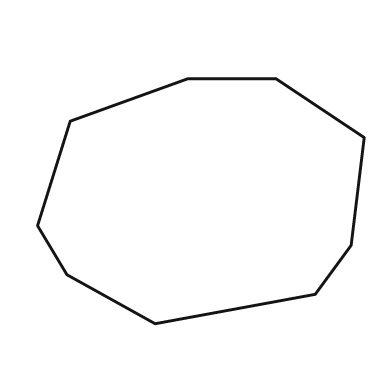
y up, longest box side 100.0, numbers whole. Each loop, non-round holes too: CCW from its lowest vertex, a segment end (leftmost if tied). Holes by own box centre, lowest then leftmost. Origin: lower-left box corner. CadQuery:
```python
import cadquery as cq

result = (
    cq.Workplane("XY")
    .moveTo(36.0, 0.0)
    .lineTo(85.0, 9.0)
    .lineTo(96.0, 24.0)
    .lineTo(100.0, 57.0)
    .lineTo(73.0, 75.0)
    .lineTo(46.0, 75.0)
    .lineTo(10.0, 62.0)
    .lineTo(0.0, 30.0)
    .lineTo(9.0, 15.0)
    .close()
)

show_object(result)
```